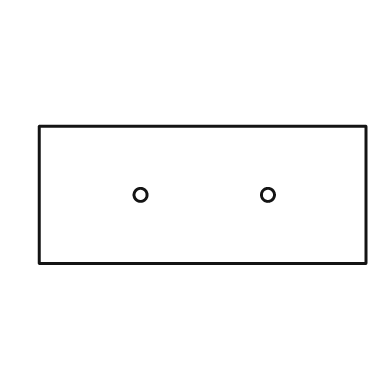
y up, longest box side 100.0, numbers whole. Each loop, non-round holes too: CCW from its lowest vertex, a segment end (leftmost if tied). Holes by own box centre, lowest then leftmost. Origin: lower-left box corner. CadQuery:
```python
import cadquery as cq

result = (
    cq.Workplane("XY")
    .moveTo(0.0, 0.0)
    .lineTo(100.0, 0.0)
    .lineTo(100.0, 42.0)
    .lineTo(0.0, 42.0)
    .close()
    .moveTo(31.0, 21.0)
    .circle(2.0)
    .moveTo(70.0, 21.0)
    .circle(2.0)
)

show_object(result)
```